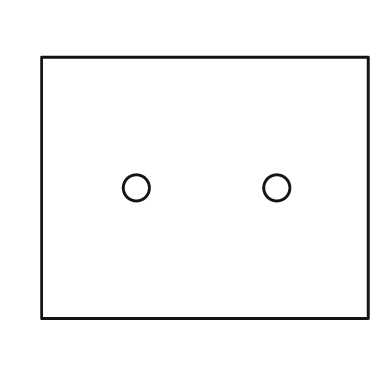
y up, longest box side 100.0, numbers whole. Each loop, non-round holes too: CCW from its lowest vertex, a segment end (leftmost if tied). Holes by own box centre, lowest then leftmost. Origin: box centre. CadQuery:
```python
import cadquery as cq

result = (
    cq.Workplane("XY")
    .moveTo(-50.0, -40.0)
    .lineTo(50.0, -40.0)
    .lineTo(50.0, 40.0)
    .lineTo(-50.0, 40.0)
    .close()
    .moveTo(-21.0, 0.0)
    .circle(4.0)
    .moveTo(22.0, 0.0)
    .circle(4.0)
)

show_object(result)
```